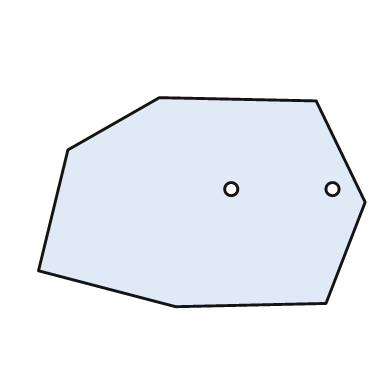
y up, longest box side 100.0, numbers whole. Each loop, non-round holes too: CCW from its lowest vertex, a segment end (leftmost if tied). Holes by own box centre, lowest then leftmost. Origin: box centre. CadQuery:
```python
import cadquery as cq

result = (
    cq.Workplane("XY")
    .moveTo(-8.0, -32.0)
    .lineTo(38.0, -31.0)
    .lineTo(50.0, 0.0)
    .lineTo(35.0, 31.0)
    .lineTo(-13.0, 32.0)
    .lineTo(-41.0, 16.0)
    .lineTo(-50.0, -21.0)
    .close()
    .moveTo(9.0, 4.0)
    .circle(2.0)
    .moveTo(40.0, 4.0)
    .circle(2.0)
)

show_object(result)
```